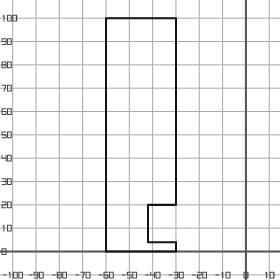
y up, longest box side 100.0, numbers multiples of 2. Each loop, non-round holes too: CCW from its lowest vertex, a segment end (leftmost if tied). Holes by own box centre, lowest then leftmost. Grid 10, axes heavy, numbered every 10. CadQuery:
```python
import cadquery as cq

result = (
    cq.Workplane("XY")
    .moveTo(-60.0, 0.0)
    .lineTo(-30.0, 0.0)
    .lineTo(-30.0, 4.0)
    .lineTo(-42.0, 4.0)
    .lineTo(-42.0, 20.0)
    .lineTo(-30.0, 20.0)
    .lineTo(-30.0, 100.0)
    .lineTo(-60.0, 100.0)
    .close()
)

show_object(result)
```